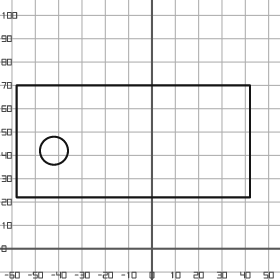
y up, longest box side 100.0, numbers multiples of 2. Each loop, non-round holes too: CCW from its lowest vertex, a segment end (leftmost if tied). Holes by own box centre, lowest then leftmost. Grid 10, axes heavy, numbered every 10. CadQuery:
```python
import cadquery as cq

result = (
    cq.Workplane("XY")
    .moveTo(-58.0, 22.0)
    .lineTo(42.0, 22.0)
    .lineTo(42.0, 70.0)
    .lineTo(-58.0, 70.0)
    .close()
    .moveTo(-42.0, 42.0)
    .circle(6.0)
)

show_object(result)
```